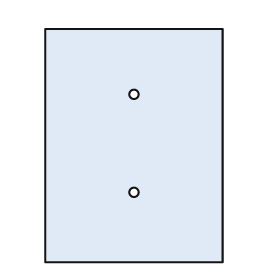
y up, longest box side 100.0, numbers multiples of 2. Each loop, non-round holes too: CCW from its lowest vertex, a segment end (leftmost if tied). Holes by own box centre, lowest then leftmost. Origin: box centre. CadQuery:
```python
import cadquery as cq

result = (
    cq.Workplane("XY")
    .moveTo(-38.0, -50.0)
    .lineTo(38.0, -50.0)
    .lineTo(38.0, 50.0)
    .lineTo(-38.0, 50.0)
    .close()
    .moveTo(0.0, -20.0)
    .circle(2.0)
    .moveTo(0.0, 22.0)
    .circle(2.0)
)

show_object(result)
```